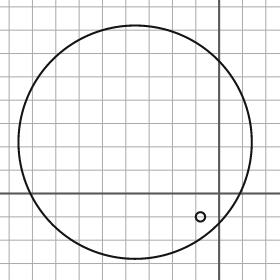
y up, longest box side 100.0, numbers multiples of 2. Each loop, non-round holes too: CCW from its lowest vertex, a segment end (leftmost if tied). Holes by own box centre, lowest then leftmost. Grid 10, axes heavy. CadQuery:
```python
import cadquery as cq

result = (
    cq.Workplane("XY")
    .moveTo(-36.0, 22.0)
    .circle(50.0)
    .moveTo(-8.0, -10.0)
    .circle(2.0)
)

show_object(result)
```